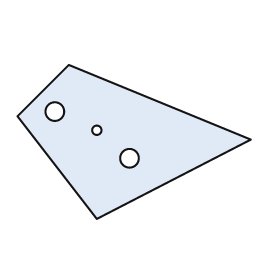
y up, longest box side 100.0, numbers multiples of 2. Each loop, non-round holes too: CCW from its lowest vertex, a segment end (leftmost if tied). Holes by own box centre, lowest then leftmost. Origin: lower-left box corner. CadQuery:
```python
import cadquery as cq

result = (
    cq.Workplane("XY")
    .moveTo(34.0, 0.0)
    .lineTo(100.0, 34.0)
    .lineTo(22.0, 66.0)
    .lineTo(0.0, 44.0)
    .close()
    .moveTo(48.0, 26.0)
    .circle(4.0)
    .moveTo(34.0, 38.0)
    .circle(2.0)
    .moveTo(16.0, 46.0)
    .circle(4.0)
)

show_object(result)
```